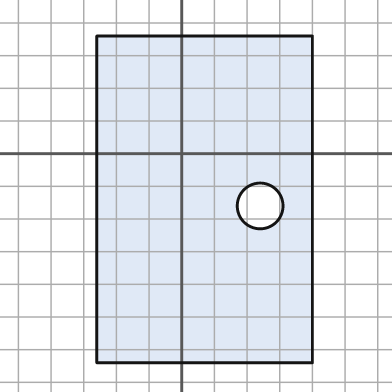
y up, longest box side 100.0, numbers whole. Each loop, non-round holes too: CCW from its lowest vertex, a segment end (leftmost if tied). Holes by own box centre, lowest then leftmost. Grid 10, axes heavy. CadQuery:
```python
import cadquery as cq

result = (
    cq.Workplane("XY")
    .moveTo(-26.0, -64.0)
    .lineTo(40.0, -64.0)
    .lineTo(40.0, 36.0)
    .lineTo(-26.0, 36.0)
    .close()
    .moveTo(24.0, -16.0)
    .circle(7.0)
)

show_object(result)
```